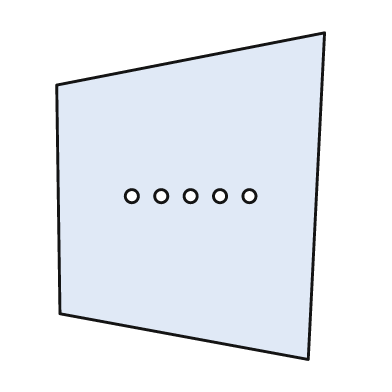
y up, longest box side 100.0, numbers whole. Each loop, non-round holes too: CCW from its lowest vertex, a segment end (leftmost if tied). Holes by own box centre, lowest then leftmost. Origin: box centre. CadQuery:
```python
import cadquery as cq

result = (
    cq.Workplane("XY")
    .moveTo(36.0, -50.0)
    .lineTo(41.0, 50.0)
    .lineTo(-41.0, 34.0)
    .lineTo(-40.0, -36.0)
    .close()
    .moveTo(-18.0, 0.0)
    .circle(2.0)
    .moveTo(-9.0, 0.0)
    .circle(2.0)
    .moveTo(0.0, 0.0)
    .circle(2.0)
    .moveTo(9.0, 0.0)
    .circle(2.0)
    .moveTo(18.0, 0.0)
    .circle(2.0)
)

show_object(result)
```